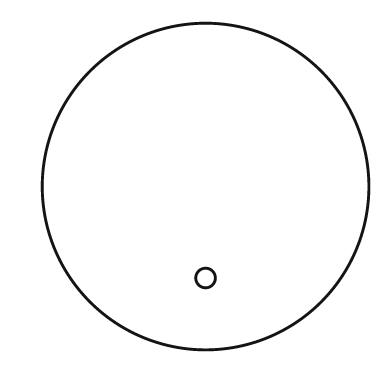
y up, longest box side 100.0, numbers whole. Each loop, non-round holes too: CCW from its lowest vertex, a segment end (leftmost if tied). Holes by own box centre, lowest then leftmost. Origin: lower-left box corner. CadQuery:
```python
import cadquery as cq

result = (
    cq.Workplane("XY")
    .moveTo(50.0, 50.0)
    .circle(50.0)
    .moveTo(50.0, 22.0)
    .circle(3.0)
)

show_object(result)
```